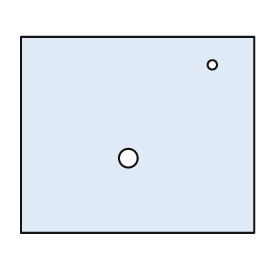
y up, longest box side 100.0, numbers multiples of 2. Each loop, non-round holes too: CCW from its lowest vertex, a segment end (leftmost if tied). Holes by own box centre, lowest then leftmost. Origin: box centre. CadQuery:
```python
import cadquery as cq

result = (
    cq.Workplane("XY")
    .moveTo(-50.0, -42.0)
    .lineTo(50.0, -42.0)
    .lineTo(50.0, 42.0)
    .lineTo(-50.0, 42.0)
    .close()
    .moveTo(-4.0, -10.0)
    .circle(4.0)
    .moveTo(32.0, 30.0)
    .circle(2.0)
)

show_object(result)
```